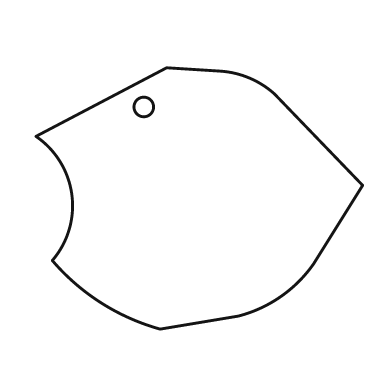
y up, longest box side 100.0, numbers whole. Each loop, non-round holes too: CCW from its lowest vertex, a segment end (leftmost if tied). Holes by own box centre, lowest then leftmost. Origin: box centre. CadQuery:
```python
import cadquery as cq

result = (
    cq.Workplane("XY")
    .moveTo(-12.0, -40.0)
    .lineTo(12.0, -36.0)
    .threePointArc((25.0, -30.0), (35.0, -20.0))
    .lineTo(50.0, 4.0)
    .lineTo(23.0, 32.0)
    .threePointArc((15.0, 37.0), (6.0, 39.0))
    .lineTo(-10.0, 40.0)
    .lineTo(-50.0, 19.0)
    .threePointArc((-39.0, 1.0), (-45.0, -19.0))
    .threePointArc((-30.0, -32.0), (-12.0, -40.0))
    .close()
    .moveTo(-17.0, 28.0)
    .circle(3.0)
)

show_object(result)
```